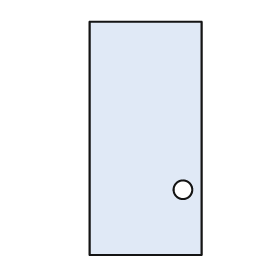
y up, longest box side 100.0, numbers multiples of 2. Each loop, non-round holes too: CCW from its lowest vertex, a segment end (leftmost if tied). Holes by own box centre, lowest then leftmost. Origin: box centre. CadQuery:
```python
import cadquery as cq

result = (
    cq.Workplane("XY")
    .moveTo(-24.0, -50.0)
    .lineTo(24.0, -50.0)
    .lineTo(24.0, 50.0)
    .lineTo(-24.0, 50.0)
    .close()
    .moveTo(16.0, -22.0)
    .circle(4.0)
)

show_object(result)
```